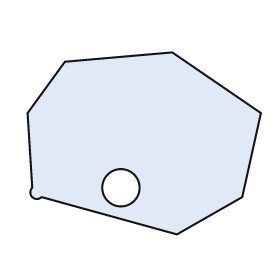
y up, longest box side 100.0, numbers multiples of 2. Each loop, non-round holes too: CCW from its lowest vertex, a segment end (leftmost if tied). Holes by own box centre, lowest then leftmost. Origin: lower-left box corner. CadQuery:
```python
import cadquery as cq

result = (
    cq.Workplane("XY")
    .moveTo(64.0, 0.0)
    .lineTo(92.0, 16.0)
    .lineTo(100.0, 52.0)
    .lineTo(62.0, 78.0)
    .lineTo(16.0, 74.0)
    .lineTo(0.0, 52.0)
    .lineTo(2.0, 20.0)
    .threePointArc((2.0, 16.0), (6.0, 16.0))
    .close()
    .moveTo(40.0, 20.0)
    .circle(8.0)
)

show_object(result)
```